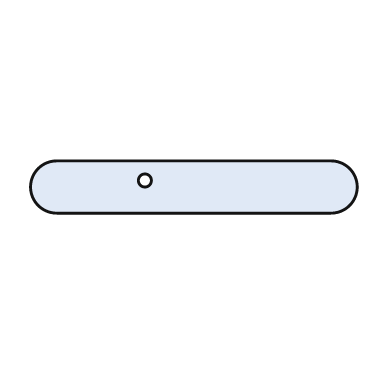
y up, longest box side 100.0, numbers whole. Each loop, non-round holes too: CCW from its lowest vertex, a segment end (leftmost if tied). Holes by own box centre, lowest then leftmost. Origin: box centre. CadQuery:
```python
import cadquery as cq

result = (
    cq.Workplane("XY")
    .moveTo(-42.0, -8.0)
    .lineTo(42.0, -8.0)
    .threePointArc((50.0, 0.0), (42.0, 8.0))
    .lineTo(-42.0, 8.0)
    .threePointArc((-50.0, 0.0), (-42.0, -8.0))
    .close()
    .moveTo(-15.0, 2.0)
    .circle(2.0)
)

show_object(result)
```